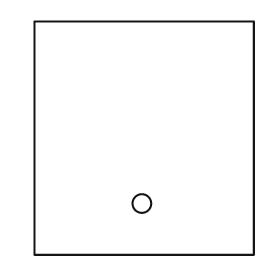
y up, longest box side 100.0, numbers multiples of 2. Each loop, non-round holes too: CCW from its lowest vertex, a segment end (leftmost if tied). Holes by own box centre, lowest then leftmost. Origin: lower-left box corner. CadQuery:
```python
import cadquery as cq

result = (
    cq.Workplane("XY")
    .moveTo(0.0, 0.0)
    .lineTo(94.0, 0.0)
    .lineTo(94.0, 100.0)
    .lineTo(0.0, 100.0)
    .close()
    .moveTo(46.0, 22.0)
    .circle(4.0)
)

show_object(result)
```